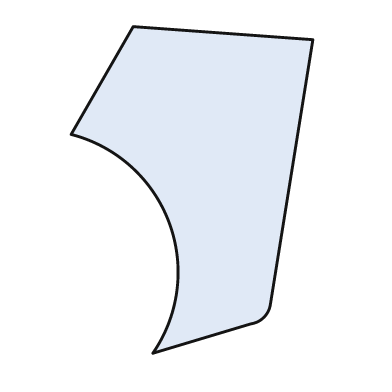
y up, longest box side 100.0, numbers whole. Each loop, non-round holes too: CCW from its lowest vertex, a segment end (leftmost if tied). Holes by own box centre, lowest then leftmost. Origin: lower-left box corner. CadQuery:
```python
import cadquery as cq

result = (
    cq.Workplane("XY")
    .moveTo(25.0, 0.0)
    .lineTo(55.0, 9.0)
    .threePointArc((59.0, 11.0), (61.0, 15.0))
    .lineTo(74.0, 96.0)
    .lineTo(19.0, 100.0)
    .lineTo(0.0, 67.0)
    .threePointArc((30.0, 40.0), (25.0, 0.0))
    .close()
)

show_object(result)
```